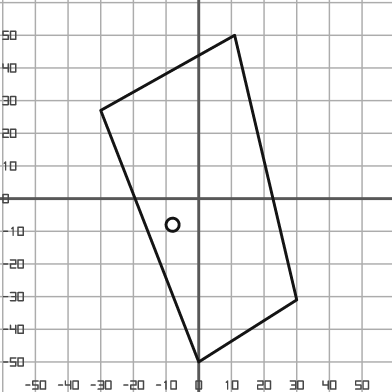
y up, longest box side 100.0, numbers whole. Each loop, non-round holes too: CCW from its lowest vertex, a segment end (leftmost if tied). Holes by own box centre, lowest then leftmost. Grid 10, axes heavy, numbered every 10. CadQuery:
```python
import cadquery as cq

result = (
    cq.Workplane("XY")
    .moveTo(0.0, -50.0)
    .lineTo(30.0, -31.0)
    .lineTo(11.0, 50.0)
    .lineTo(-30.0, 27.0)
    .close()
    .moveTo(-8.0, -8.0)
    .circle(2.0)
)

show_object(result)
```